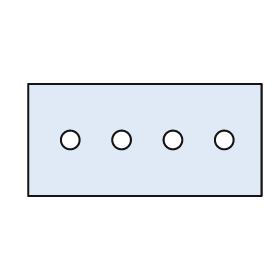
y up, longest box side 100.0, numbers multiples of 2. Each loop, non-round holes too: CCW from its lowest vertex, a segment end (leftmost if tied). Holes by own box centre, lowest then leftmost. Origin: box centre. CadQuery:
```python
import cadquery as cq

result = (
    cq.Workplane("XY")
    .moveTo(-50.0, -24.0)
    .lineTo(50.0, -24.0)
    .lineTo(50.0, 24.0)
    .lineTo(-50.0, 24.0)
    .close()
    .moveTo(-32.0, 0.0)
    .circle(4.0)
    .moveTo(-10.0, 0.0)
    .circle(4.0)
    .moveTo(12.0, 0.0)
    .circle(4.0)
    .moveTo(34.0, 0.0)
    .circle(4.0)
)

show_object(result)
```